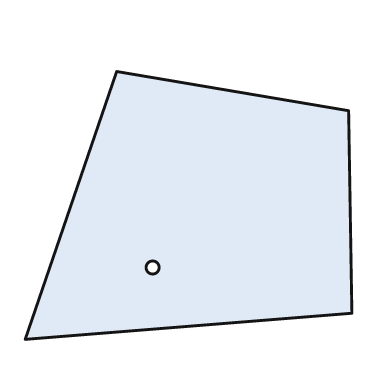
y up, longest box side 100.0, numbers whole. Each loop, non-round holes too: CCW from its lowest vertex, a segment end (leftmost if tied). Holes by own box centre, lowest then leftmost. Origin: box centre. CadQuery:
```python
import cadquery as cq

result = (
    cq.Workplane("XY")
    .moveTo(-50.0, -41.0)
    .lineTo(50.0, -33.0)
    .lineTo(49.0, 29.0)
    .lineTo(-22.0, 41.0)
    .close()
    .moveTo(-11.0, -19.0)
    .circle(2.0)
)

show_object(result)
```